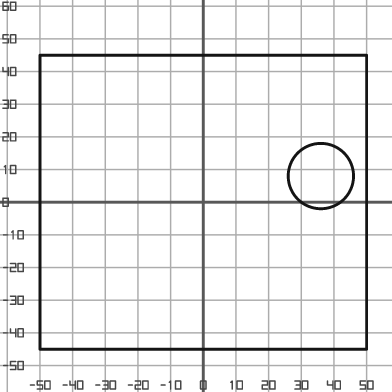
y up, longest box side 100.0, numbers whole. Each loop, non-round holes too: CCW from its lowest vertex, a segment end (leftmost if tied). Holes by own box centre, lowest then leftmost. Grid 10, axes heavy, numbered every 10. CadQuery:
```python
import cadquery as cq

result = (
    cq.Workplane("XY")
    .moveTo(-50.0, -45.0)
    .lineTo(50.0, -45.0)
    .lineTo(50.0, 45.0)
    .lineTo(-50.0, 45.0)
    .close()
    .moveTo(36.0, 8.0)
    .circle(10.0)
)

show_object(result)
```